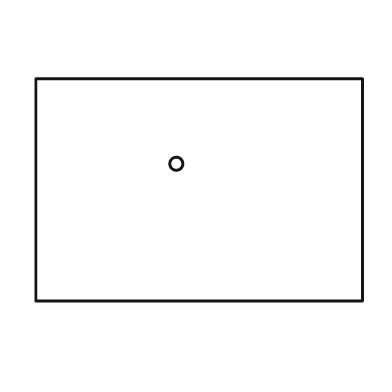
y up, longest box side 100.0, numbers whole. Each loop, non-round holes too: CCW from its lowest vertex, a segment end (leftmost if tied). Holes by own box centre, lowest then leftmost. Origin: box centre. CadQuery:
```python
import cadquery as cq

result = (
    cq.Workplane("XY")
    .moveTo(-50.0, -34.0)
    .lineTo(50.0, -34.0)
    .lineTo(50.0, 34.0)
    .lineTo(-50.0, 34.0)
    .close()
    .moveTo(-7.0, 8.0)
    .circle(2.0)
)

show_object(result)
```